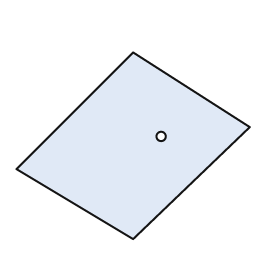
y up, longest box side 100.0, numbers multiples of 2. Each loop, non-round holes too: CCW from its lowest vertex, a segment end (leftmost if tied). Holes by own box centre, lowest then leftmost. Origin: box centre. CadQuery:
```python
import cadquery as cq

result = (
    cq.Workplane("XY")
    .moveTo(0.0, -40.0)
    .lineTo(50.0, 8.0)
    .lineTo(0.0, 40.0)
    .lineTo(-50.0, -10.0)
    .close()
    .moveTo(12.0, 4.0)
    .circle(2.0)
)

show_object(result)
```